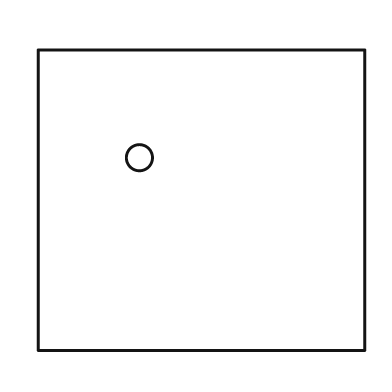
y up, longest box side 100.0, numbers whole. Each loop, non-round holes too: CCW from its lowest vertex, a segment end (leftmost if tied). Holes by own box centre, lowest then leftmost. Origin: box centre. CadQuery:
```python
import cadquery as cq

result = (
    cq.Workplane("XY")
    .moveTo(-50.0, -46.0)
    .lineTo(50.0, -46.0)
    .lineTo(50.0, 46.0)
    .lineTo(-50.0, 46.0)
    .close()
    .moveTo(-19.0, 13.0)
    .circle(4.0)
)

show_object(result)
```